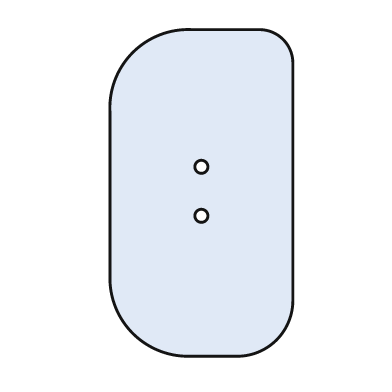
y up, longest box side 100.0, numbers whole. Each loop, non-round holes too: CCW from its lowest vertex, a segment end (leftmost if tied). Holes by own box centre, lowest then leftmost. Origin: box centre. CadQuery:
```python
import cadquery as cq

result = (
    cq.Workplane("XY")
    .moveTo(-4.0, -50.0)
    .lineTo(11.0, -50.0)
    .threePointArc((23.0, -45.0), (28.0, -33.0))
    .lineTo(28.0, 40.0)
    .threePointArc((25.0, 47.0), (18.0, 50.0))
    .lineTo(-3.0, 50.0)
    .threePointArc((-21.0, 43.0), (-28.0, 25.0))
    .lineTo(-28.0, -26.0)
    .threePointArc((-21.0, -43.0), (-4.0, -50.0))
    .close()
    .moveTo(0.0, -7.0)
    .circle(2.0)
    .moveTo(0.0, 8.0)
    .circle(2.0)
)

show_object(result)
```